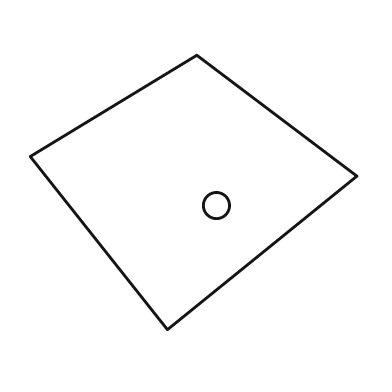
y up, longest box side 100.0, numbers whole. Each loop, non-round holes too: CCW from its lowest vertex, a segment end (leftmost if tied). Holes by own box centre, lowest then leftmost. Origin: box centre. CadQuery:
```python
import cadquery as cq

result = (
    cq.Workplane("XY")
    .moveTo(-8.0, -42.0)
    .lineTo(50.0, 5.0)
    .lineTo(1.0, 42.0)
    .lineTo(-50.0, 11.0)
    .close()
    .moveTo(7.0, -4.0)
    .circle(4.0)
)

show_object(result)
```